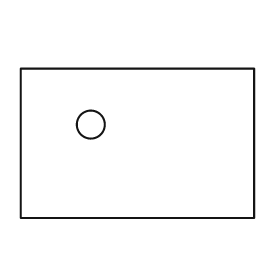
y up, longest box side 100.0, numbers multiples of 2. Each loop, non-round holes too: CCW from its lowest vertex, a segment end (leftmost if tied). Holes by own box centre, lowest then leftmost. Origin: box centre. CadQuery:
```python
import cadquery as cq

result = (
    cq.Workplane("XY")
    .moveTo(-50.0, -32.0)
    .lineTo(50.0, -32.0)
    .lineTo(50.0, 32.0)
    .lineTo(-50.0, 32.0)
    .close()
    .moveTo(-20.0, 8.0)
    .circle(6.0)
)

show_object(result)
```